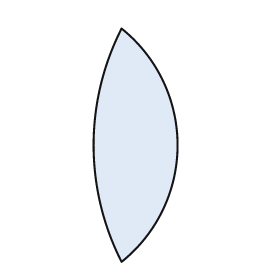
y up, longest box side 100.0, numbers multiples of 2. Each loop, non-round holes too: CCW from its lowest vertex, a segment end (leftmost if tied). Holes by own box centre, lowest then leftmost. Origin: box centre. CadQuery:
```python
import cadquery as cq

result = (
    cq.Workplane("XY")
    .moveTo(-6.0, -50.0)
    .threePointArc((18.0, 0.0), (-6.0, 50.0))
    .threePointArc((-18.0, 0.0), (-6.0, -50.0))
    .close()
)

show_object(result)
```